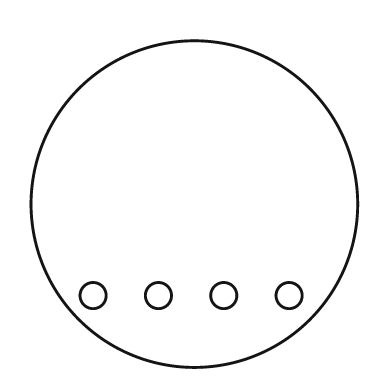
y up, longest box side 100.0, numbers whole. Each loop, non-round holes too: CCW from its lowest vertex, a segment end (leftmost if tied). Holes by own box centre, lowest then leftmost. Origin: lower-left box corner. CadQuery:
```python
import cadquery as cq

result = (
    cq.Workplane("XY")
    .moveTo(50.0, 50.0)
    .circle(50.0)
    .moveTo(19.0, 22.0)
    .circle(4.0)
    .moveTo(39.0, 22.0)
    .circle(4.0)
    .moveTo(59.0, 22.0)
    .circle(4.0)
    .moveTo(79.0, 22.0)
    .circle(4.0)
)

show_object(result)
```